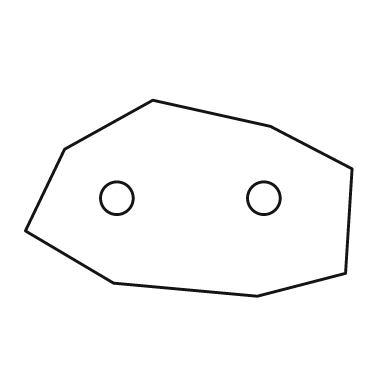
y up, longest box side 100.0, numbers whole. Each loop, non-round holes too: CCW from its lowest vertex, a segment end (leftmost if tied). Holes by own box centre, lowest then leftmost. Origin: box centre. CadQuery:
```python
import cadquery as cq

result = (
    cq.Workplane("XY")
    .moveTo(21.0, -30.0)
    .lineTo(48.0, -23.0)
    .lineTo(50.0, 9.0)
    .lineTo(25.0, 22.0)
    .lineTo(-11.0, 30.0)
    .lineTo(-38.0, 15.0)
    .lineTo(-50.0, -10.0)
    .lineTo(-23.0, -26.0)
    .close()
    .moveTo(-22.0, 0.0)
    .circle(5.0)
    .moveTo(23.0, 0.0)
    .circle(5.0)
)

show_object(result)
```